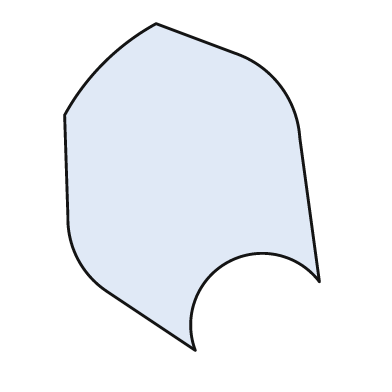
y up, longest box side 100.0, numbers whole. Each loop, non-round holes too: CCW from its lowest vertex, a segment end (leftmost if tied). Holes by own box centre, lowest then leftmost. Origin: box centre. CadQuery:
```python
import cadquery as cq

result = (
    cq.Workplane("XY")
    .moveTo(1.0, -50.0)
    .threePointArc((11.0, -23.0), (39.0, -29.0))
    .lineTo(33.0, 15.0)
    .threePointArc((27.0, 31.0), (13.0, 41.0))
    .lineTo(-11.0, 50.0)
    .threePointArc((-27.0, 38.0), (-39.0, 22.0))
    .lineTo(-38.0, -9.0)
    .threePointArc((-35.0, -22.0), (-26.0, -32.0))
    .close()
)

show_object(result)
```